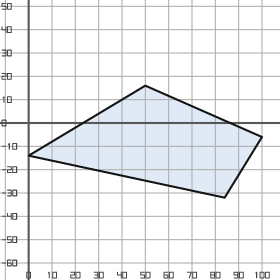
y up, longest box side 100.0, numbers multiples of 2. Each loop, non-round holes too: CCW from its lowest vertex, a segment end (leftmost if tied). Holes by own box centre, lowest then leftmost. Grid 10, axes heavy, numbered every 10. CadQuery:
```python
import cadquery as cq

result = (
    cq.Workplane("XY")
    .moveTo(84.0, -32.0)
    .lineTo(100.0, -6.0)
    .lineTo(50.0, 16.0)
    .lineTo(0.0, -14.0)
    .close()
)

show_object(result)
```